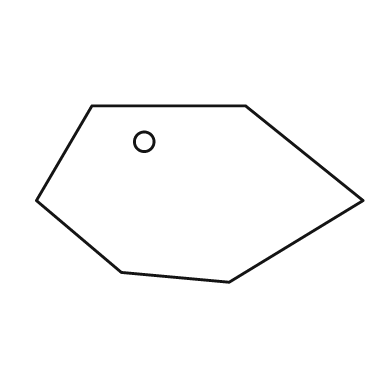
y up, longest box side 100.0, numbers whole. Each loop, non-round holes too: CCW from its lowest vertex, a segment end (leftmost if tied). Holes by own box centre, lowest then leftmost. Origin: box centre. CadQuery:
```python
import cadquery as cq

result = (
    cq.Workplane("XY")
    .moveTo(9.0, -27.0)
    .lineTo(50.0, -2.0)
    .lineTo(14.0, 27.0)
    .lineTo(-33.0, 27.0)
    .lineTo(-50.0, -2.0)
    .lineTo(-24.0, -24.0)
    .close()
    .moveTo(-17.0, 16.0)
    .circle(3.0)
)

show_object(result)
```